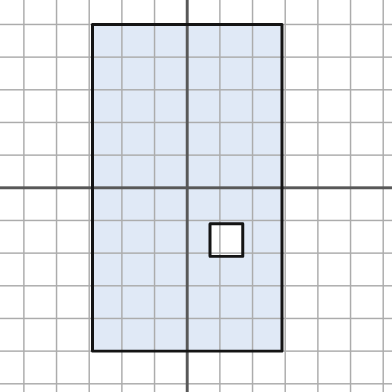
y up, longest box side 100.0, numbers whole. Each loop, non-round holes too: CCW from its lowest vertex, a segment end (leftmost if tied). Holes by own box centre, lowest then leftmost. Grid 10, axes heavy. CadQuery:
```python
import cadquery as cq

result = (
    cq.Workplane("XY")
    .moveTo(-29.0, -50.0)
    .lineTo(29.0, -50.0)
    .lineTo(29.0, 50.0)
    .lineTo(-29.0, 50.0)
    .close()
    .moveTo(7.0, -21.0)
    .lineTo(17.0, -21.0)
    .lineTo(17.0, -11.0)
    .lineTo(7.0, -11.0)
    .close()
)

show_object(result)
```